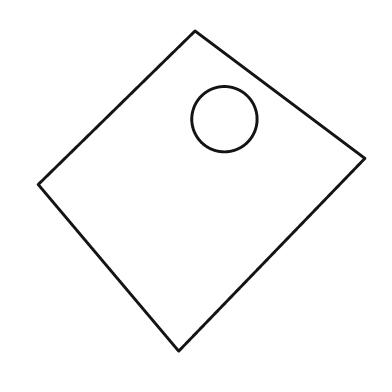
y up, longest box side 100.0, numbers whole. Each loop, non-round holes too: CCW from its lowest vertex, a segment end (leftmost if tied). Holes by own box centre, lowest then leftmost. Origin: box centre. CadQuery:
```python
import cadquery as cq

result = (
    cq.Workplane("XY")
    .moveTo(-7.0, -49.0)
    .lineTo(50.0, 10.0)
    .lineTo(-2.0, 49.0)
    .lineTo(-50.0, 2.0)
    .close()
    .moveTo(7.0, 22.0)
    .circle(10.0)
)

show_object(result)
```